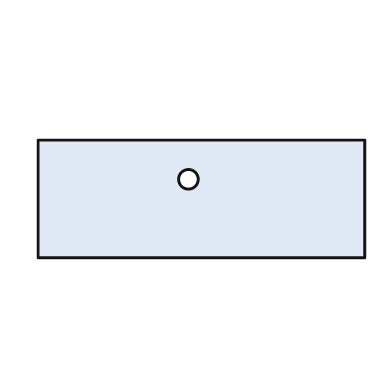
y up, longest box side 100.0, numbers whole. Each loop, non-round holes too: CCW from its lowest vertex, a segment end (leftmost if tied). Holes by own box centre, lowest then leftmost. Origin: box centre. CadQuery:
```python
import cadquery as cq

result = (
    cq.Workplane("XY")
    .moveTo(-50.0, -18.0)
    .lineTo(50.0, -18.0)
    .lineTo(50.0, 18.0)
    .lineTo(-50.0, 18.0)
    .close()
    .moveTo(-4.0, 6.0)
    .circle(3.0)
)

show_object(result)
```